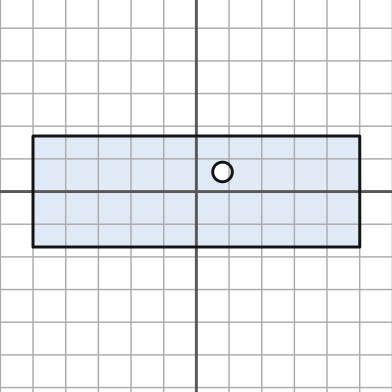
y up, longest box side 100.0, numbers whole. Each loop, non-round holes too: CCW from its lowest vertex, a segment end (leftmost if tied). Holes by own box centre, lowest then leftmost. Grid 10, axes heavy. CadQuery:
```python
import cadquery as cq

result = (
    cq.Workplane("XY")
    .moveTo(-50.0, -17.0)
    .lineTo(50.0, -17.0)
    .lineTo(50.0, 17.0)
    .lineTo(-50.0, 17.0)
    .close()
    .moveTo(8.0, 6.0)
    .circle(3.0)
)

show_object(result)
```